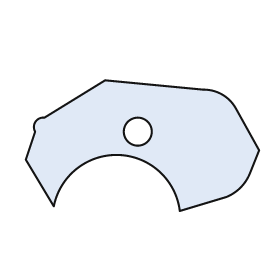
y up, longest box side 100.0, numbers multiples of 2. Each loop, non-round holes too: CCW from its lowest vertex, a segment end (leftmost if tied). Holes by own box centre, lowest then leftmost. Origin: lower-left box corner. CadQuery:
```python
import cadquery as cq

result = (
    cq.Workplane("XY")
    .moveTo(66.0, 0.0)
    .lineTo(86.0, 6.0)
    .threePointArc((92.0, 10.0), (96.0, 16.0))
    .lineTo(100.0, 26.0)
    .lineTo(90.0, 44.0)
    .threePointArc((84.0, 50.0), (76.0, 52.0))
    .lineTo(34.0, 56.0)
    .lineTo(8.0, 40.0)
    .threePointArc((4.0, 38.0), (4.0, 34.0))
    .lineTo(0.0, 22.0)
    .lineTo(12.0, 2.0)
    .threePointArc((40.0, 24.0), (66.0, 0.0))
    .close()
    .moveTo(48.0, 34.0)
    .circle(6.0)
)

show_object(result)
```